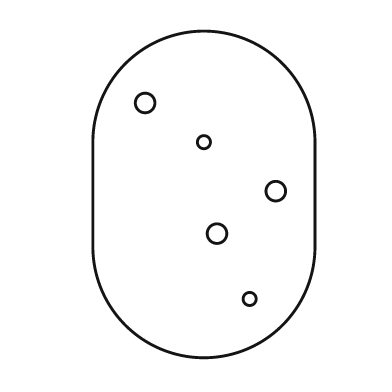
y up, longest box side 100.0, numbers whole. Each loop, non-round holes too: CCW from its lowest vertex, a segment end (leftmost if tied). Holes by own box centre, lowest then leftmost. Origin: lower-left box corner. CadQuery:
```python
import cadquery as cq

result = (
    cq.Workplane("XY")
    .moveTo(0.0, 34.0)
    .threePointArc((34.0, 0.0), (68.0, 34.0))
    .lineTo(68.0, 66.0)
    .threePointArc((34.0, 100.0), (0.0, 66.0))
    .close()
    .moveTo(48.0, 18.0)
    .circle(2.0)
    .moveTo(38.0, 38.0)
    .circle(3.0)
    .moveTo(56.0, 51.0)
    .circle(3.0)
    .moveTo(34.0, 66.0)
    .circle(2.0)
    .moveTo(16.0, 78.0)
    .circle(3.0)
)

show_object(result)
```